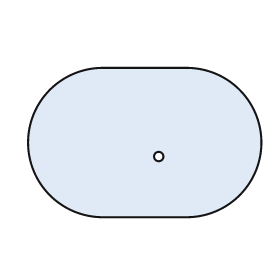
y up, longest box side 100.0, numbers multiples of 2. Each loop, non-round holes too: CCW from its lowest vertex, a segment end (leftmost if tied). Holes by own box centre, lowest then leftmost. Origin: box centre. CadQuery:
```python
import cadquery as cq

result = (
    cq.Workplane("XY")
    .moveTo(-18.0, -32.0)
    .lineTo(18.0, -32.0)
    .threePointArc((50.0, 0.0), (18.0, 32.0))
    .lineTo(-18.0, 32.0)
    .threePointArc((-50.0, 0.0), (-18.0, -32.0))
    .close()
    .moveTo(6.0, -6.0)
    .circle(2.0)
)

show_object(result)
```